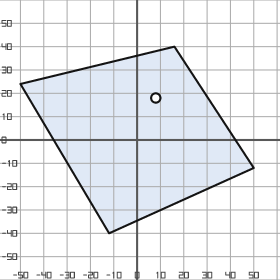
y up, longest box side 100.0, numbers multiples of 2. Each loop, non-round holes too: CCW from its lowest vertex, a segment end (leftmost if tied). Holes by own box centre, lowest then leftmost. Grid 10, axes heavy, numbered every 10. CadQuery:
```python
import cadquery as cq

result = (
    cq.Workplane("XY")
    .moveTo(-12.0, -40.0)
    .lineTo(50.0, -12.0)
    .lineTo(16.0, 40.0)
    .lineTo(-50.0, 24.0)
    .close()
    .moveTo(8.0, 18.0)
    .circle(2.0)
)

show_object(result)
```